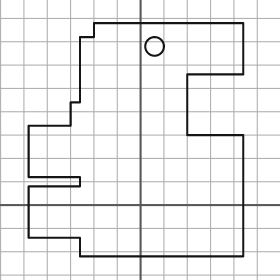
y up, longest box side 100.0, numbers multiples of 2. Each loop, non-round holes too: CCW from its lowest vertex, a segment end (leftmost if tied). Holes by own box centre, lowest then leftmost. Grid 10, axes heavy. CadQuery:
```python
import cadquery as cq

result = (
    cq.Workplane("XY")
    .moveTo(-26.0, -22.0)
    .lineTo(44.0, -22.0)
    .lineTo(44.0, 30.0)
    .lineTo(20.0, 30.0)
    .lineTo(20.0, 56.0)
    .lineTo(44.0, 56.0)
    .lineTo(44.0, 78.0)
    .lineTo(-20.0, 78.0)
    .lineTo(-20.0, 72.0)
    .lineTo(-26.0, 72.0)
    .lineTo(-26.0, 44.0)
    .lineTo(-30.0, 44.0)
    .lineTo(-30.0, 34.0)
    .lineTo(-48.0, 34.0)
    .lineTo(-48.0, 12.0)
    .lineTo(-26.0, 12.0)
    .lineTo(-26.0, 8.0)
    .lineTo(-48.0, 8.0)
    .lineTo(-48.0, -14.0)
    .lineTo(-26.0, -14.0)
    .close()
    .moveTo(6.0, 68.0)
    .circle(4.0)
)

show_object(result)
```